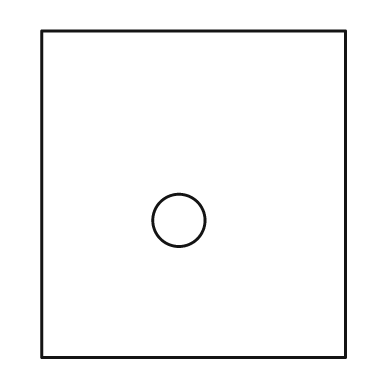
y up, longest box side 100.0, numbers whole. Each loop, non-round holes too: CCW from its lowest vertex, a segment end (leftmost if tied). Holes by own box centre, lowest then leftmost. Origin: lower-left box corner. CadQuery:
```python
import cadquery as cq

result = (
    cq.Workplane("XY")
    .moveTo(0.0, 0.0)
    .lineTo(93.0, 0.0)
    .lineTo(93.0, 100.0)
    .lineTo(0.0, 100.0)
    .close()
    .moveTo(42.0, 42.0)
    .circle(8.0)
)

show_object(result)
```